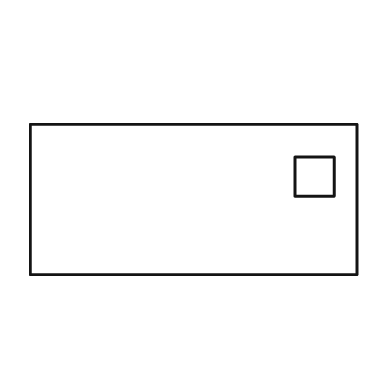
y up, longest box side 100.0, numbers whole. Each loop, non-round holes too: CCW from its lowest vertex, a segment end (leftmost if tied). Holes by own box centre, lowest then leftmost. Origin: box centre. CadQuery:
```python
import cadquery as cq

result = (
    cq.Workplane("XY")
    .moveTo(-50.0, -23.0)
    .lineTo(50.0, -23.0)
    .lineTo(50.0, 23.0)
    .lineTo(-50.0, 23.0)
    .close()
    .moveTo(31.0, 1.0)
    .lineTo(43.0, 1.0)
    .lineTo(43.0, 13.0)
    .lineTo(31.0, 13.0)
    .close()
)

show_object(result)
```